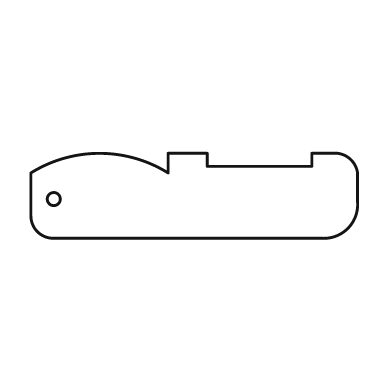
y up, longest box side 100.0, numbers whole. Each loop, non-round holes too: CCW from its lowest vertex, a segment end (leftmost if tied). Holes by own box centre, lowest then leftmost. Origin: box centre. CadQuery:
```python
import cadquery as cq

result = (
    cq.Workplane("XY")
    .moveTo(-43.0, -13.0)
    .lineTo(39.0, -13.0)
    .threePointArc((47.0, -10.0), (50.0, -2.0))
    .lineTo(50.0, 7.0)
    .threePointArc((48.0, 11.0), (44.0, 13.0))
    .lineTo(36.0, 13.0)
    .lineTo(36.0, 9.0)
    .lineTo(4.0, 9.0)
    .lineTo(4.0, 13.0)
    .lineTo(-8.0, 13.0)
    .lineTo(-8.0, 7.0)
    .threePointArc((-29.0, 13.0), (-50.0, 7.0))
    .lineTo(-50.0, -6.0)
    .threePointArc((-48.0, -11.0), (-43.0, -13.0))
    .close()
    .moveTo(-43.0, -1.0)
    .circle(2.0)
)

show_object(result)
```